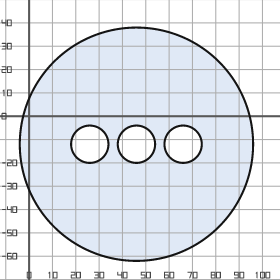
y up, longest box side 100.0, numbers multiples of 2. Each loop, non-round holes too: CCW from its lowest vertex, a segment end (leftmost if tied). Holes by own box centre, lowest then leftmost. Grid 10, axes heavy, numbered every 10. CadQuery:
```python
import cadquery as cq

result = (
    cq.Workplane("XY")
    .moveTo(46.0, -12.0)
    .circle(50.0)
    .moveTo(26.0, -12.0)
    .circle(8.0)
    .moveTo(46.0, -12.0)
    .circle(8.0)
    .moveTo(66.0, -12.0)
    .circle(8.0)
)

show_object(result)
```